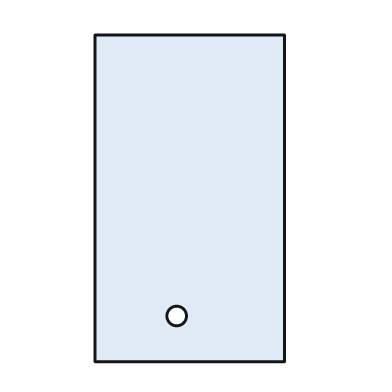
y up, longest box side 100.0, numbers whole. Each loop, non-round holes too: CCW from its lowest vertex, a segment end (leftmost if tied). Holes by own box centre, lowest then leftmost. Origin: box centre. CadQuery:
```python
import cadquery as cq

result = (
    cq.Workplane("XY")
    .moveTo(-29.0, -50.0)
    .lineTo(29.0, -50.0)
    .lineTo(29.0, 50.0)
    .lineTo(-29.0, 50.0)
    .close()
    .moveTo(-4.0, -36.0)
    .circle(3.0)
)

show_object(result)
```